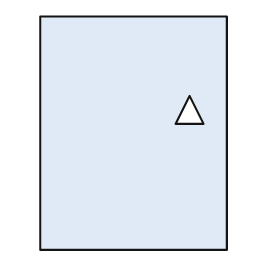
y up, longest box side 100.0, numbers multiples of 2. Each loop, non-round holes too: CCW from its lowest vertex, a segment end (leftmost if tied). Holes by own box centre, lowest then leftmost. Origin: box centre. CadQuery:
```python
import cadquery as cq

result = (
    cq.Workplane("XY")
    .moveTo(-40.0, -50.0)
    .lineTo(40.0, -50.0)
    .lineTo(40.0, 50.0)
    .lineTo(-40.0, 50.0)
    .close()
    .moveTo(18.0, 4.0)
    .lineTo(30.0, 4.0)
    .lineTo(24.0, 16.0)
    .close()
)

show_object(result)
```